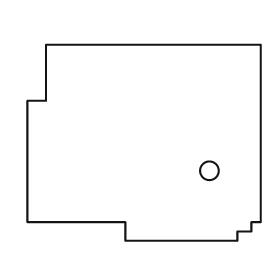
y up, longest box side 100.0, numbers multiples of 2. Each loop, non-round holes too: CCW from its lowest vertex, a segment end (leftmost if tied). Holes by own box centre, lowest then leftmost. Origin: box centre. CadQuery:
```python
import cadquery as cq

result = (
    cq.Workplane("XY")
    .moveTo(-8.0, -42.0)
    .lineTo(40.0, -42.0)
    .lineTo(40.0, -38.0)
    .lineTo(46.0, -38.0)
    .lineTo(46.0, -34.0)
    .lineTo(50.0, -34.0)
    .lineTo(50.0, 42.0)
    .lineTo(-42.0, 42.0)
    .lineTo(-42.0, 18.0)
    .lineTo(-50.0, 18.0)
    .lineTo(-50.0, -34.0)
    .lineTo(-8.0, -34.0)
    .close()
    .moveTo(28.0, -12.0)
    .circle(4.0)
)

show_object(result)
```